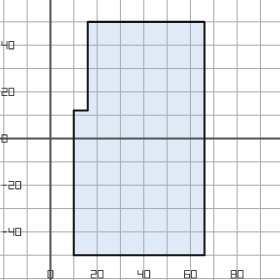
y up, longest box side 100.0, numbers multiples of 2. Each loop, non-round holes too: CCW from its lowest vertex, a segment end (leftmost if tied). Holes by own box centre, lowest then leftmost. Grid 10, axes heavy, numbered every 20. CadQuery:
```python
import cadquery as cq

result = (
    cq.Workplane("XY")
    .moveTo(10.0, -50.0)
    .lineTo(66.0, -50.0)
    .lineTo(66.0, 50.0)
    .lineTo(16.0, 50.0)
    .lineTo(16.0, 12.0)
    .lineTo(10.0, 12.0)
    .close()
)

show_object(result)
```